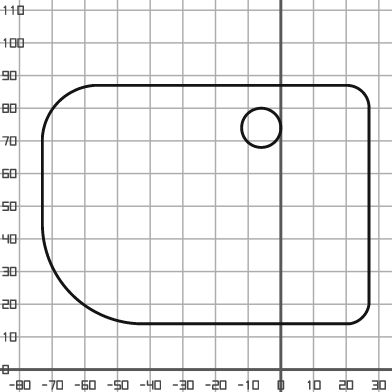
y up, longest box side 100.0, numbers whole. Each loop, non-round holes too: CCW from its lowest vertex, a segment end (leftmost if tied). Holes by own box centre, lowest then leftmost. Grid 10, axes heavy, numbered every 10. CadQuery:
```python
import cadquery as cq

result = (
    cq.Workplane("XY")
    .moveTo(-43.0, 14.0)
    .lineTo(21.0, 14.0)
    .threePointArc((25.0, 16.0), (27.0, 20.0))
    .lineTo(27.0, 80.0)
    .threePointArc((25.0, 85.0), (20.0, 87.0))
    .lineTo(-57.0, 87.0)
    .threePointArc((-68.0, 82.0), (-73.0, 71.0))
    .lineTo(-73.0, 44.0)
    .threePointArc((-64.0, 23.0), (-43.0, 14.0))
    .close()
    .moveTo(-6.0, 74.0)
    .circle(6.0)
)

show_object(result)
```